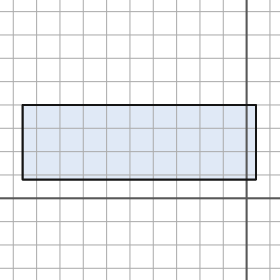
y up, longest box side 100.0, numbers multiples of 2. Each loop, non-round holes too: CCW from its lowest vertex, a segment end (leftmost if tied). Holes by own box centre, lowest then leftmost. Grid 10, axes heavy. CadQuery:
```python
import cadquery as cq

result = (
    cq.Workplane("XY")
    .moveTo(-96.0, 8.0)
    .lineTo(4.0, 8.0)
    .lineTo(4.0, 40.0)
    .lineTo(-96.0, 40.0)
    .close()
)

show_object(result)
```